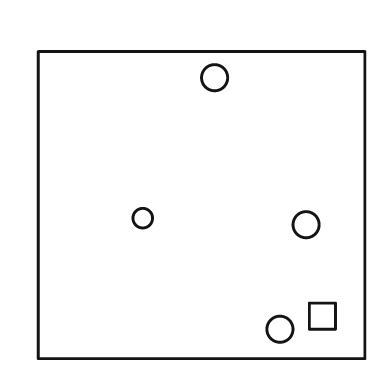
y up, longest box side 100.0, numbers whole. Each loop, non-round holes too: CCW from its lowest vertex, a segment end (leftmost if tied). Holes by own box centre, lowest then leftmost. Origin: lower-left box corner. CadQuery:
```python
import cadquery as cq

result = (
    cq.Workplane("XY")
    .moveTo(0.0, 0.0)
    .lineTo(100.0, 0.0)
    .lineTo(100.0, 94.0)
    .lineTo(0.0, 94.0)
    .close()
    .moveTo(74.0, 9.0)
    .circle(4.0)
    .moveTo(83.0, 9.0)
    .lineTo(91.0, 9.0)
    .lineTo(91.0, 17.0)
    .lineTo(83.0, 17.0)
    .close()
    .moveTo(82.0, 41.0)
    .circle(4.0)
    .moveTo(32.0, 43.0)
    .circle(3.0)
    .moveTo(54.0, 86.0)
    .circle(4.0)
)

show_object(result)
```